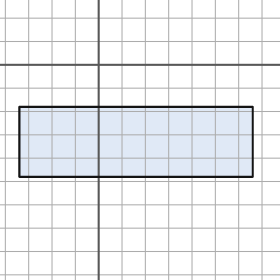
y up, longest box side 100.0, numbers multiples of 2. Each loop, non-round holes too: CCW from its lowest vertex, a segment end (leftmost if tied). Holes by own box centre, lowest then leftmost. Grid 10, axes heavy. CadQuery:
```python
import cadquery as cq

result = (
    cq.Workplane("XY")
    .moveTo(-34.0, -48.0)
    .lineTo(66.0, -48.0)
    .lineTo(66.0, -18.0)
    .lineTo(-34.0, -18.0)
    .close()
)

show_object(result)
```